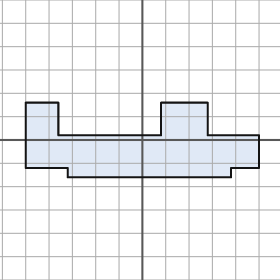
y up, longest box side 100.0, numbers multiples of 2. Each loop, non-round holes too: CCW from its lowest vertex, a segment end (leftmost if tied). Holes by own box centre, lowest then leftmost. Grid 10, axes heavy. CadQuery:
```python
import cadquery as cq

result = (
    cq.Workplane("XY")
    .moveTo(-32.0, -16.0)
    .lineTo(38.0, -16.0)
    .lineTo(38.0, -12.0)
    .lineTo(50.0, -12.0)
    .lineTo(50.0, 2.0)
    .lineTo(28.0, 2.0)
    .lineTo(28.0, 16.0)
    .lineTo(8.0, 16.0)
    .lineTo(8.0, 2.0)
    .lineTo(-36.0, 2.0)
    .lineTo(-36.0, 16.0)
    .lineTo(-50.0, 16.0)
    .lineTo(-50.0, -12.0)
    .lineTo(-32.0, -12.0)
    .close()
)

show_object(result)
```